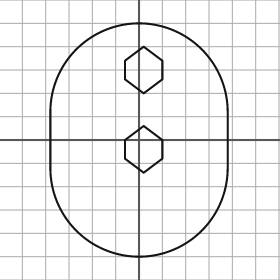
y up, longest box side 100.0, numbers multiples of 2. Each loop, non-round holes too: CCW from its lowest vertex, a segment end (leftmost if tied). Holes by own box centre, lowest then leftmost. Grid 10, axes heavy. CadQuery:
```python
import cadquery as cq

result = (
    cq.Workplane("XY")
    .moveTo(-38.0, -12.0)
    .threePointArc((0.0, -50.0), (38.0, -12.0))
    .lineTo(38.0, 12.0)
    .threePointArc((0.0, 50.0), (-38.0, 12.0))
    .close()
    .moveTo(2.0, -14.0)
    .lineTo(10.0, -8.0)
    .lineTo(10.0, 0.0)
    .lineTo(2.0, 6.0)
    .lineTo(-6.0, 0.0)
    .lineTo(-6.0, -8.0)
    .close()
    .moveTo(2.0, 20.0)
    .lineTo(10.0, 26.0)
    .lineTo(10.0, 34.0)
    .lineTo(2.0, 40.0)
    .lineTo(-6.0, 34.0)
    .lineTo(-6.0, 26.0)
    .close()
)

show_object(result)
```